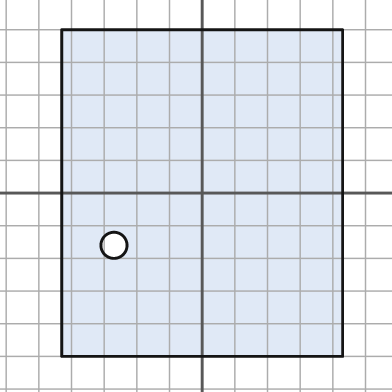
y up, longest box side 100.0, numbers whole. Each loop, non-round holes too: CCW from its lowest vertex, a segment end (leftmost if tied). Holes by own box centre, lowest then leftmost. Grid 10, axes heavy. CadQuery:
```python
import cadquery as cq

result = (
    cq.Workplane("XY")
    .moveTo(-43.0, -50.0)
    .lineTo(43.0, -50.0)
    .lineTo(43.0, 50.0)
    .lineTo(-43.0, 50.0)
    .close()
    .moveTo(-27.0, -16.0)
    .circle(4.0)
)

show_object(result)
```